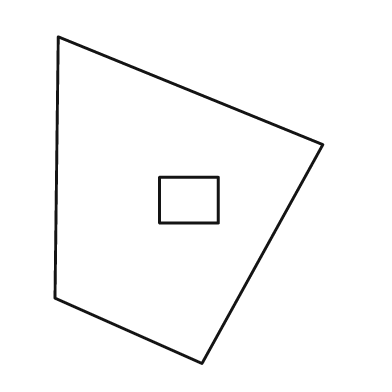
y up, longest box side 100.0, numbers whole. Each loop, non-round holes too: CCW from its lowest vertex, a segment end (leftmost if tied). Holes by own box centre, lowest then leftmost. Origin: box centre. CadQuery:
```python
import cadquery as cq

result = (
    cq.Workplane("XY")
    .moveTo(4.0, -50.0)
    .lineTo(41.0, 17.0)
    .lineTo(-40.0, 50.0)
    .lineTo(-41.0, -30.0)
    .close()
    .moveTo(-9.0, -7.0)
    .lineTo(9.0, -7.0)
    .lineTo(9.0, 7.0)
    .lineTo(-9.0, 7.0)
    .close()
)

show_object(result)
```